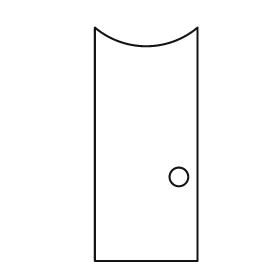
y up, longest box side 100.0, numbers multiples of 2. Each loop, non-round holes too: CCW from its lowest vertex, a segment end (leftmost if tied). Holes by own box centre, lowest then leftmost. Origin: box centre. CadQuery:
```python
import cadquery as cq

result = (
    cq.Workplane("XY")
    .moveTo(-22.0, -50.0)
    .lineTo(22.0, -50.0)
    .lineTo(22.0, 50.0)
    .threePointArc((0.0, 42.0), (-22.0, 50.0))
    .close()
    .moveTo(14.0, -14.0)
    .circle(4.0)
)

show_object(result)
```